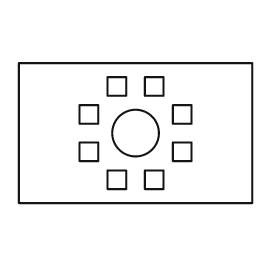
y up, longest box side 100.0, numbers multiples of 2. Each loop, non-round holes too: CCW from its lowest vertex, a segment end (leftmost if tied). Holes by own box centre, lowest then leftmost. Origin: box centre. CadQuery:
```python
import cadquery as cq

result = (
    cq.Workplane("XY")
    .moveTo(-50.0, -30.0)
    .lineTo(50.0, -30.0)
    .lineTo(50.0, 30.0)
    .lineTo(-50.0, 30.0)
    .close()
    .moveTo(-12.0, -24.0)
    .lineTo(-4.0, -24.0)
    .lineTo(-4.0, -16.0)
    .lineTo(-12.0, -16.0)
    .close()
    .moveTo(4.0, -24.0)
    .lineTo(12.0, -24.0)
    .lineTo(12.0, -16.0)
    .lineTo(4.0, -16.0)
    .close()
    .moveTo(-24.0, -12.0)
    .lineTo(-16.0, -12.0)
    .lineTo(-16.0, -4.0)
    .lineTo(-24.0, -4.0)
    .close()
    .moveTo(16.0, -12.0)
    .lineTo(24.0, -12.0)
    .lineTo(24.0, -4.0)
    .lineTo(16.0, -4.0)
    .close()
    .moveTo(0.0, 0.0)
    .circle(10.0)
    .moveTo(-24.0, 4.0)
    .lineTo(-16.0, 4.0)
    .lineTo(-16.0, 12.0)
    .lineTo(-24.0, 12.0)
    .close()
    .moveTo(16.0, 4.0)
    .lineTo(24.0, 4.0)
    .lineTo(24.0, 12.0)
    .lineTo(16.0, 12.0)
    .close()
    .moveTo(-12.0, 16.0)
    .lineTo(-4.0, 16.0)
    .lineTo(-4.0, 24.0)
    .lineTo(-12.0, 24.0)
    .close()
    .moveTo(4.0, 16.0)
    .lineTo(12.0, 16.0)
    .lineTo(12.0, 24.0)
    .lineTo(4.0, 24.0)
    .close()
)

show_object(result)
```